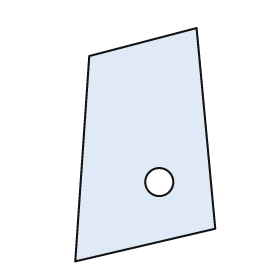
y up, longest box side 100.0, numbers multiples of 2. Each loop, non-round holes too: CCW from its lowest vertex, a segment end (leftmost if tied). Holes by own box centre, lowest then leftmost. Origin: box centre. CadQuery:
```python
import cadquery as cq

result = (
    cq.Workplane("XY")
    .moveTo(-30.0, -50.0)
    .lineTo(30.0, -36.0)
    .lineTo(22.0, 50.0)
    .lineTo(-24.0, 38.0)
    .close()
    .moveTo(6.0, -16.0)
    .circle(6.0)
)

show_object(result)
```